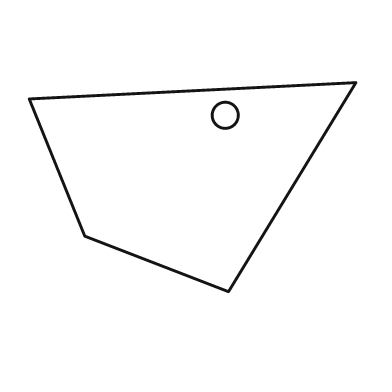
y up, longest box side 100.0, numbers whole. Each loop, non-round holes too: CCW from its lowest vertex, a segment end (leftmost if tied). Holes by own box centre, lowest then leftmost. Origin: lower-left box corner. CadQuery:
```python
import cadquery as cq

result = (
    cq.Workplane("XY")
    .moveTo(61.0, 0.0)
    .lineTo(100.0, 64.0)
    .lineTo(0.0, 59.0)
    .lineTo(17.0, 17.0)
    .close()
    .moveTo(60.0, 54.0)
    .circle(4.0)
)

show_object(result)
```